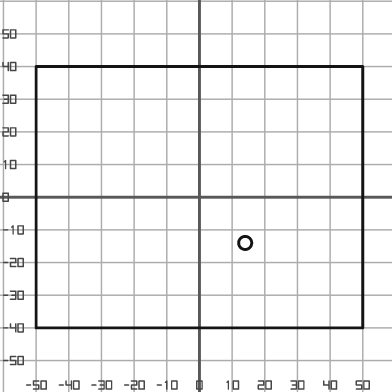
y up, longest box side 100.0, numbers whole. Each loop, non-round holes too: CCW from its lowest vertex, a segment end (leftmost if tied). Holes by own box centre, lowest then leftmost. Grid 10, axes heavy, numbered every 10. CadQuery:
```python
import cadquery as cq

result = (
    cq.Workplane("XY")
    .moveTo(-50.0, -40.0)
    .lineTo(50.0, -40.0)
    .lineTo(50.0, 40.0)
    .lineTo(-50.0, 40.0)
    .close()
    .moveTo(14.0, -14.0)
    .circle(2.0)
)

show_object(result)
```